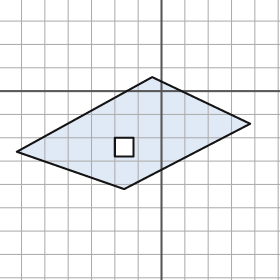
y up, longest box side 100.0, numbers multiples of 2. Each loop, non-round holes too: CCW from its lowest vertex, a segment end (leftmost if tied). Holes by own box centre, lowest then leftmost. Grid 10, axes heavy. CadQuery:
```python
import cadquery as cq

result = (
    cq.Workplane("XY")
    .moveTo(-16.0, -42.0)
    .lineTo(38.0, -14.0)
    .lineTo(-4.0, 6.0)
    .lineTo(-62.0, -26.0)
    .close()
    .moveTo(-20.0, -28.0)
    .lineTo(-12.0, -28.0)
    .lineTo(-12.0, -20.0)
    .lineTo(-20.0, -20.0)
    .close()
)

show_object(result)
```